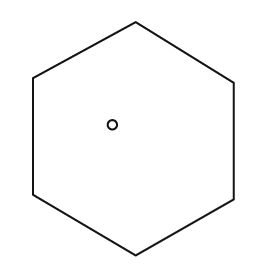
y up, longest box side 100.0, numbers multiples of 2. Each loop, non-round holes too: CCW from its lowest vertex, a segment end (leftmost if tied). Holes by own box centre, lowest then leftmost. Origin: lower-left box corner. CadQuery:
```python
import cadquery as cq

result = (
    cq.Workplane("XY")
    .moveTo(44.0, 0.0)
    .lineTo(86.0, 24.0)
    .lineTo(86.0, 74.0)
    .lineTo(44.0, 100.0)
    .lineTo(0.0, 76.0)
    .lineTo(0.0, 26.0)
    .close()
    .moveTo(34.0, 56.0)
    .circle(2.0)
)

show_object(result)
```